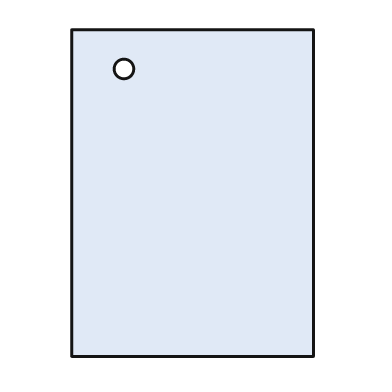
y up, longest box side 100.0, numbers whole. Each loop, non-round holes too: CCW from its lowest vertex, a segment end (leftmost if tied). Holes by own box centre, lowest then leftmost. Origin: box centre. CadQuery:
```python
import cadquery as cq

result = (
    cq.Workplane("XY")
    .moveTo(-37.0, -50.0)
    .lineTo(37.0, -50.0)
    .lineTo(37.0, 50.0)
    .lineTo(-37.0, 50.0)
    .close()
    .moveTo(-21.0, 38.0)
    .circle(3.0)
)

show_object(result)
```